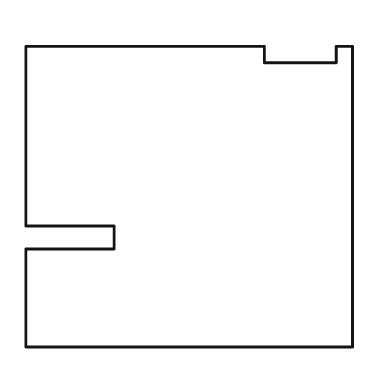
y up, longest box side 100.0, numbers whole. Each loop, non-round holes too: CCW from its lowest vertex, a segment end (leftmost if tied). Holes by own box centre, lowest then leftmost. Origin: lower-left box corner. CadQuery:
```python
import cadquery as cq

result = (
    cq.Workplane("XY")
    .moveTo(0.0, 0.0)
    .lineTo(100.0, 0.0)
    .lineTo(100.0, 92.0)
    .lineTo(95.0, 92.0)
    .lineTo(95.0, 87.0)
    .lineTo(73.0, 87.0)
    .lineTo(73.0, 92.0)
    .lineTo(0.0, 92.0)
    .lineTo(0.0, 37.0)
    .lineTo(27.0, 37.0)
    .lineTo(27.0, 30.0)
    .lineTo(0.0, 30.0)
    .close()
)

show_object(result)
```